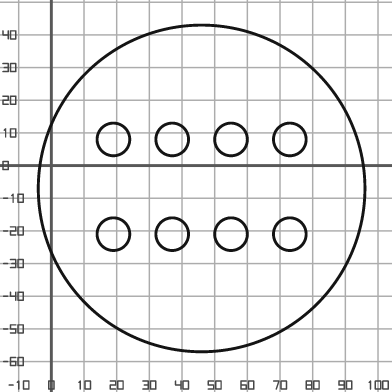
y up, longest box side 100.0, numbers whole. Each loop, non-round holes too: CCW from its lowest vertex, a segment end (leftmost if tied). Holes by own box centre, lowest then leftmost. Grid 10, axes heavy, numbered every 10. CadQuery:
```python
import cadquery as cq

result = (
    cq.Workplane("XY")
    .moveTo(46.0, -7.0)
    .circle(50.0)
    .moveTo(19.0, -21.0)
    .circle(5.0)
    .moveTo(37.0, -21.0)
    .circle(5.0)
    .moveTo(55.0, -21.0)
    .circle(5.0)
    .moveTo(73.0, -21.0)
    .circle(5.0)
    .moveTo(19.0, 8.0)
    .circle(5.0)
    .moveTo(37.0, 8.0)
    .circle(5.0)
    .moveTo(55.0, 8.0)
    .circle(5.0)
    .moveTo(73.0, 8.0)
    .circle(5.0)
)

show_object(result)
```